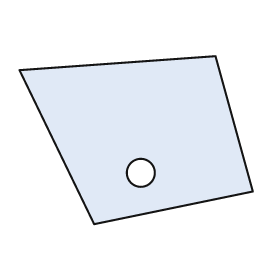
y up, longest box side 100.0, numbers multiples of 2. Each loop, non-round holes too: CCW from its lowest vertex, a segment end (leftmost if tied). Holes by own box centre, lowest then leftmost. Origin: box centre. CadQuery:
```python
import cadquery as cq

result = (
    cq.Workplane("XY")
    .moveTo(-18.0, -36.0)
    .lineTo(50.0, -22.0)
    .lineTo(34.0, 36.0)
    .lineTo(-50.0, 30.0)
    .close()
    .moveTo(2.0, -14.0)
    .circle(6.0)
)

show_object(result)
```